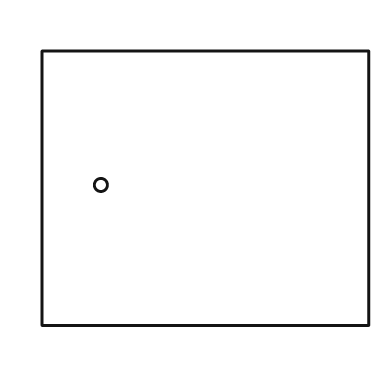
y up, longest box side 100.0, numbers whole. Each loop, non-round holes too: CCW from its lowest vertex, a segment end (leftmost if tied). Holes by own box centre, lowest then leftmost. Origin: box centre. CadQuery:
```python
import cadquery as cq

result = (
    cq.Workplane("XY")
    .moveTo(-50.0, -42.0)
    .lineTo(50.0, -42.0)
    .lineTo(50.0, 42.0)
    .lineTo(-50.0, 42.0)
    .close()
    .moveTo(-32.0, 1.0)
    .circle(2.0)
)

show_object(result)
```